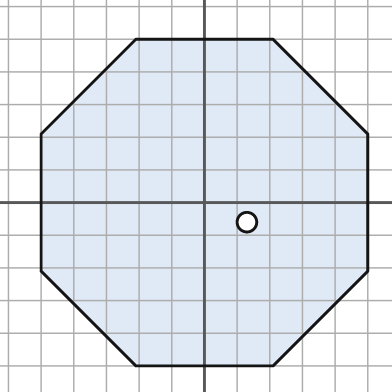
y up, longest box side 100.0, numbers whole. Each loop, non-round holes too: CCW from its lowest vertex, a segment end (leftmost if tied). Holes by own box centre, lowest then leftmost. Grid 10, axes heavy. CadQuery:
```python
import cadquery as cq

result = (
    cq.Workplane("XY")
    .moveTo(-21.0, -50.0)
    .lineTo(21.0, -50.0)
    .lineTo(50.0, -21.0)
    .lineTo(50.0, 21.0)
    .lineTo(21.0, 50.0)
    .lineTo(-21.0, 50.0)
    .lineTo(-50.0, 21.0)
    .lineTo(-50.0, -21.0)
    .close()
    .moveTo(13.0, -6.0)
    .circle(3.0)
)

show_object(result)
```